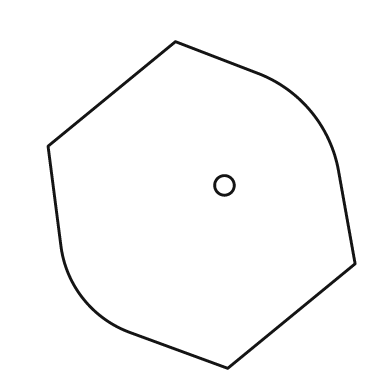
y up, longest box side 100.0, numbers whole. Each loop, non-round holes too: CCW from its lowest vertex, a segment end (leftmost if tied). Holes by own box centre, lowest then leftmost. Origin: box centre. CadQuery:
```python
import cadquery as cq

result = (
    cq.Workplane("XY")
    .moveTo(8.0, -50.0)
    .lineTo(47.0, -18.0)
    .lineTo(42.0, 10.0)
    .threePointArc((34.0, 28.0), (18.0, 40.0))
    .lineTo(-8.0, 50.0)
    .lineTo(-47.0, 18.0)
    .lineTo(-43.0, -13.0)
    .threePointArc((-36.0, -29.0), (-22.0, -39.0))
    .close()
    .moveTo(7.0, 6.0)
    .circle(3.0)
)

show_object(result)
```